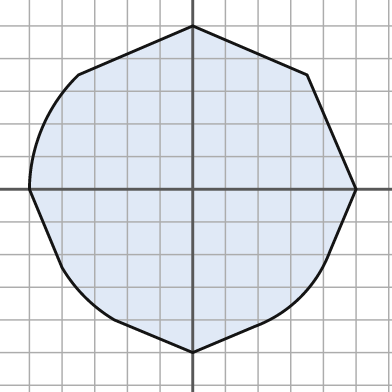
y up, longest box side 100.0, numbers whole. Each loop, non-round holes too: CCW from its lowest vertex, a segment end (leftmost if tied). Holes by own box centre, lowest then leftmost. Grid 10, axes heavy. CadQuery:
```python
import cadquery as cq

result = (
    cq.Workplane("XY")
    .moveTo(0.0, -50.0)
    .lineTo(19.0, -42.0)
    .threePointArc((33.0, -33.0), (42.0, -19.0))
    .lineTo(50.0, 0.0)
    .lineTo(35.0, 35.0)
    .lineTo(0.0, 50.0)
    .lineTo(-35.0, 35.0)
    .threePointArc((-46.0, 19.0), (-50.0, 0.0))
    .lineTo(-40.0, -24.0)
    .threePointArc((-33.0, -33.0), (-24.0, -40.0))
    .close()
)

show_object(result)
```